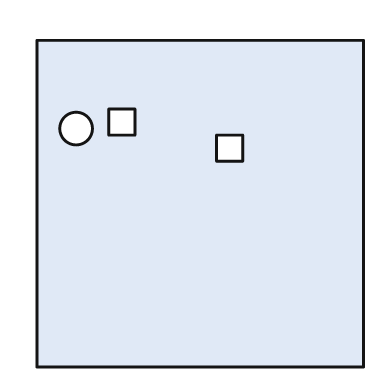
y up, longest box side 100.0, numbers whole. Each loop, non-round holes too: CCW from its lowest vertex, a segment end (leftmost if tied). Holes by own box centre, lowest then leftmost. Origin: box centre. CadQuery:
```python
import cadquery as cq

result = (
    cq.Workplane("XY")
    .moveTo(-50.0, -50.0)
    .lineTo(50.0, -50.0)
    .lineTo(50.0, 50.0)
    .lineTo(-50.0, 50.0)
    .close()
    .moveTo(5.0, 13.0)
    .lineTo(13.0, 13.0)
    .lineTo(13.0, 21.0)
    .lineTo(5.0, 21.0)
    .close()
    .moveTo(-38.0, 23.0)
    .circle(5.0)
    .moveTo(-28.0, 21.0)
    .lineTo(-20.0, 21.0)
    .lineTo(-20.0, 29.0)
    .lineTo(-28.0, 29.0)
    .close()
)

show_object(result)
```